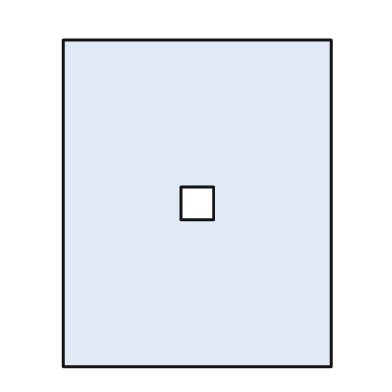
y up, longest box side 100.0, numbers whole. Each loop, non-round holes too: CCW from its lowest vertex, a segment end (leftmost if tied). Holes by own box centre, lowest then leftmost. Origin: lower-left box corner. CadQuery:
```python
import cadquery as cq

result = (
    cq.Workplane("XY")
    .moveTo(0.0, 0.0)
    .lineTo(82.0, 0.0)
    .lineTo(82.0, 100.0)
    .lineTo(0.0, 100.0)
    .close()
    .moveTo(36.0, 45.0)
    .lineTo(46.0, 45.0)
    .lineTo(46.0, 55.0)
    .lineTo(36.0, 55.0)
    .close()
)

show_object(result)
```